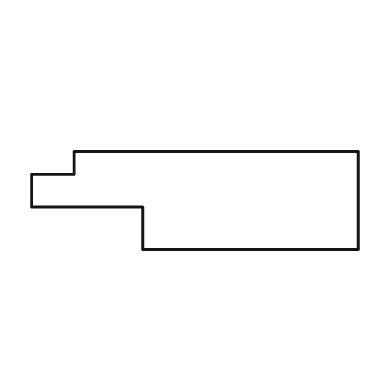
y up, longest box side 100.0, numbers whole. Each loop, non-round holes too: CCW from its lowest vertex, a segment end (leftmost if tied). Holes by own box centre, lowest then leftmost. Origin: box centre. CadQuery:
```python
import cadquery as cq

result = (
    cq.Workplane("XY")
    .moveTo(-16.0, -15.0)
    .lineTo(50.0, -15.0)
    .lineTo(50.0, 15.0)
    .lineTo(-37.0, 15.0)
    .lineTo(-37.0, 8.0)
    .lineTo(-50.0, 8.0)
    .lineTo(-50.0, -2.0)
    .lineTo(-16.0, -2.0)
    .close()
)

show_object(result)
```